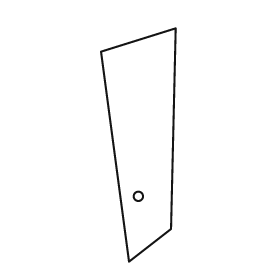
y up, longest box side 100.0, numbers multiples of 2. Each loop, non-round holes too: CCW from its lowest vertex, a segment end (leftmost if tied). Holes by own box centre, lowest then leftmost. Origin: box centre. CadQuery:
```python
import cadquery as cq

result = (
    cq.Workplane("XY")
    .moveTo(-4.0, -50.0)
    .lineTo(14.0, -36.0)
    .lineTo(16.0, 50.0)
    .lineTo(-16.0, 40.0)
    .close()
    .moveTo(0.0, -22.0)
    .circle(2.0)
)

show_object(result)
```